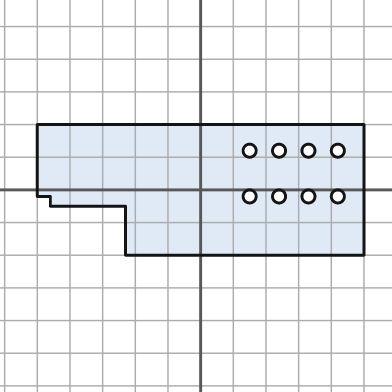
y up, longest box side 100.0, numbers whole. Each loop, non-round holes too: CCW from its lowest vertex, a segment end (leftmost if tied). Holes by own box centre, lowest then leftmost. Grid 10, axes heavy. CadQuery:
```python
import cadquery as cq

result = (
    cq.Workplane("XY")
    .moveTo(-23.0, -20.0)
    .lineTo(50.0, -20.0)
    .lineTo(50.0, 20.0)
    .lineTo(-50.0, 20.0)
    .lineTo(-50.0, -2.0)
    .lineTo(-46.0, -2.0)
    .lineTo(-46.0, -5.0)
    .lineTo(-23.0, -5.0)
    .close()
    .moveTo(15.0, -2.0)
    .circle(2.0)
    .moveTo(24.0, -2.0)
    .circle(2.0)
    .moveTo(33.0, -2.0)
    .circle(2.0)
    .moveTo(42.0, -2.0)
    .circle(2.0)
    .moveTo(15.0, 12.0)
    .circle(2.0)
    .moveTo(24.0, 12.0)
    .circle(2.0)
    .moveTo(33.0, 12.0)
    .circle(2.0)
    .moveTo(42.0, 12.0)
    .circle(2.0)
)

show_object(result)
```